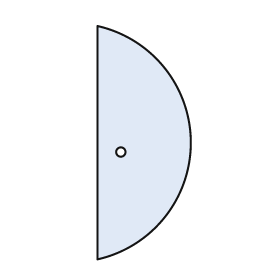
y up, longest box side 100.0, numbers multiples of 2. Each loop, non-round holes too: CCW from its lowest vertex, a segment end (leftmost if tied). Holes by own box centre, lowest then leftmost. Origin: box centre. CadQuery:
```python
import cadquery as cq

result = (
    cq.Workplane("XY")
    .moveTo(-20.0, -50.0)
    .threePointArc((20.0, 0.0), (-20.0, 50.0))
    .close()
    .moveTo(-10.0, -4.0)
    .circle(2.0)
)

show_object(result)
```